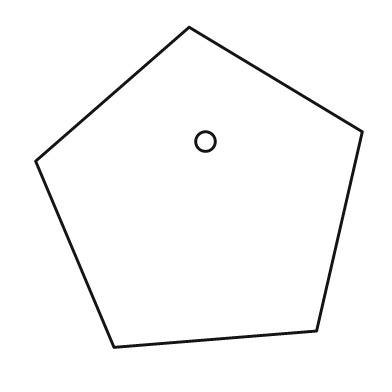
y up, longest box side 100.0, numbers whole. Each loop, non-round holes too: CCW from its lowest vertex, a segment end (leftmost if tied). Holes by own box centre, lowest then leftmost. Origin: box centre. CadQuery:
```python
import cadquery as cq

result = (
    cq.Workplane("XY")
    .moveTo(-26.0, -49.0)
    .lineTo(36.0, -44.0)
    .lineTo(50.0, 17.0)
    .lineTo(-3.0, 49.0)
    .lineTo(-50.0, 8.0)
    .close()
    .moveTo(2.0, 14.0)
    .circle(3.0)
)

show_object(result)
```